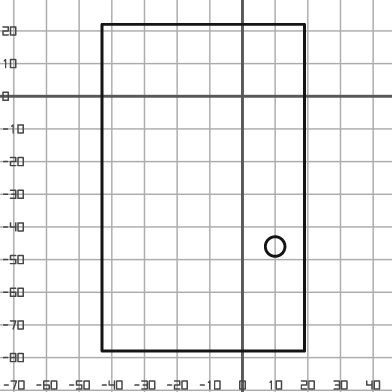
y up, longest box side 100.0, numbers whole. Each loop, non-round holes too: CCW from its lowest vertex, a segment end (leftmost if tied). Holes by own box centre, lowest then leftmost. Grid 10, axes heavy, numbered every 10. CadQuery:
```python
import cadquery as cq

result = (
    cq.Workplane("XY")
    .moveTo(-43.0, -78.0)
    .lineTo(19.0, -78.0)
    .lineTo(19.0, 22.0)
    .lineTo(-43.0, 22.0)
    .close()
    .moveTo(10.0, -46.0)
    .circle(3.0)
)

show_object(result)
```